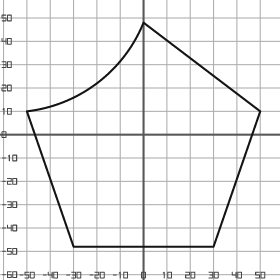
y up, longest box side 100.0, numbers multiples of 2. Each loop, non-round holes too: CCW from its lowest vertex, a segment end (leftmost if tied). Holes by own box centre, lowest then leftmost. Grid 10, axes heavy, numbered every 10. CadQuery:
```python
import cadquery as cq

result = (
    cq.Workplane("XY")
    .moveTo(-30.0, -48.0)
    .lineTo(30.0, -48.0)
    .lineTo(50.0, 10.0)
    .lineTo(0.0, 48.0)
    .threePointArc((-20.0, 22.0), (-50.0, 10.0))
    .close()
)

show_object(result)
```